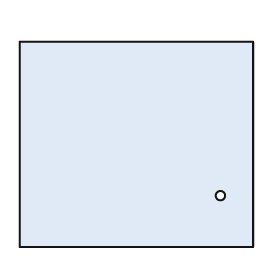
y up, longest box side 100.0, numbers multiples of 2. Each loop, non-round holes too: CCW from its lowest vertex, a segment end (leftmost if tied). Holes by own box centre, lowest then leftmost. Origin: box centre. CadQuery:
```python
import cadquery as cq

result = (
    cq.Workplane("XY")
    .moveTo(-50.0, -44.0)
    .lineTo(50.0, -44.0)
    .lineTo(50.0, 44.0)
    .lineTo(-50.0, 44.0)
    .close()
    .moveTo(36.0, -22.0)
    .circle(2.0)
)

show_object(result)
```